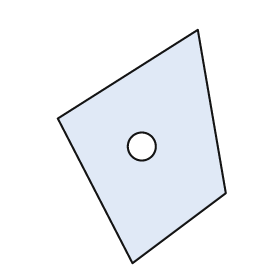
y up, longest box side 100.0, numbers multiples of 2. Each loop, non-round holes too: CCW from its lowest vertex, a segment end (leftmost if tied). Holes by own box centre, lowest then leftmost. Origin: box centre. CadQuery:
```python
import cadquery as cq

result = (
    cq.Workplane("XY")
    .moveTo(-4.0, -50.0)
    .lineTo(36.0, -20.0)
    .lineTo(24.0, 50.0)
    .lineTo(-36.0, 12.0)
    .close()
    .moveTo(0.0, 0.0)
    .circle(6.0)
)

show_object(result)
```